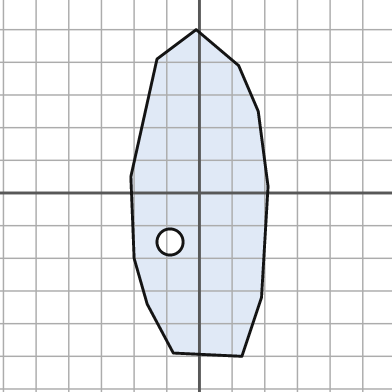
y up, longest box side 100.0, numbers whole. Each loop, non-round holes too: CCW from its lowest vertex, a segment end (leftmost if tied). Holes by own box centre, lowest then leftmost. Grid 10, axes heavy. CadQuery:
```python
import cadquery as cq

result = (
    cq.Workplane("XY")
    .moveTo(13.0, -50.0)
    .lineTo(19.0, -32.0)
    .lineTo(21.0, 2.0)
    .lineTo(18.0, 25.0)
    .lineTo(12.0, 39.0)
    .lineTo(-1.0, 50.0)
    .lineTo(-13.0, 41.0)
    .lineTo(-21.0, 5.0)
    .lineTo(-20.0, -20.0)
    .lineTo(-16.0, -34.0)
    .lineTo(-8.0, -49.0)
    .close()
    .moveTo(-9.0, -15.0)
    .circle(4.0)
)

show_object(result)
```